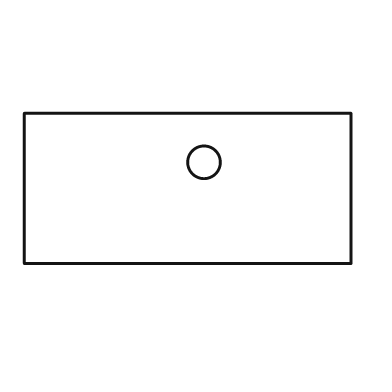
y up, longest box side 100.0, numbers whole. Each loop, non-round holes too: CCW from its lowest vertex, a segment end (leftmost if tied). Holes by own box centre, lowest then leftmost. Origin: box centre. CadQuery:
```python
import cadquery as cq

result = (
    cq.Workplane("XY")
    .moveTo(-50.0, -23.0)
    .lineTo(50.0, -23.0)
    .lineTo(50.0, 23.0)
    .lineTo(-50.0, 23.0)
    .close()
    .moveTo(5.0, 8.0)
    .circle(5.0)
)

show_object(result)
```